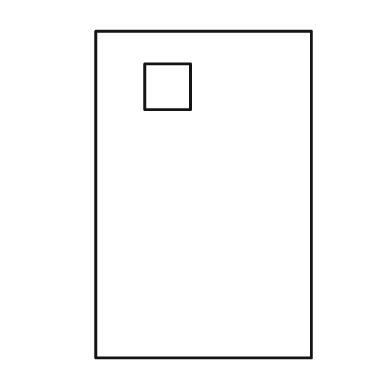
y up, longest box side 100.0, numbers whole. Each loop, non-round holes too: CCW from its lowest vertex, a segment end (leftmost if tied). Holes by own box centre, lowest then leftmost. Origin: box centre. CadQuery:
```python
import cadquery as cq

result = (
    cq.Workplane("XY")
    .moveTo(-33.0, -50.0)
    .lineTo(33.0, -50.0)
    .lineTo(33.0, 50.0)
    .lineTo(-33.0, 50.0)
    .close()
    .moveTo(-18.0, 26.0)
    .lineTo(-4.0, 26.0)
    .lineTo(-4.0, 40.0)
    .lineTo(-18.0, 40.0)
    .close()
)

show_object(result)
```